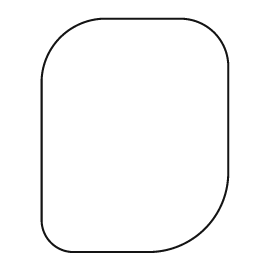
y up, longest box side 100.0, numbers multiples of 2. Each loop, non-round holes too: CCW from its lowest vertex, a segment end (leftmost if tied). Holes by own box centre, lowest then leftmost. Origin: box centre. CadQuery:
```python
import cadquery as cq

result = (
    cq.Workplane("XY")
    .moveTo(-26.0, -50.0)
    .lineTo(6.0, -50.0)
    .threePointArc((30.0, -40.0), (40.0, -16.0))
    .lineTo(40.0, 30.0)
    .threePointArc((34.0, 44.0), (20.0, 50.0))
    .lineTo(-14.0, 50.0)
    .threePointArc((-32.0, 42.0), (-40.0, 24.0))
    .lineTo(-40.0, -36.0)
    .threePointArc((-36.0, -46.0), (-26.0, -50.0))
    .close()
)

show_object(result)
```